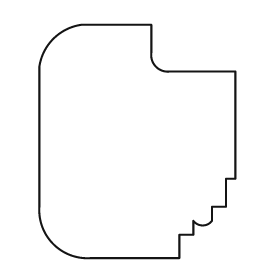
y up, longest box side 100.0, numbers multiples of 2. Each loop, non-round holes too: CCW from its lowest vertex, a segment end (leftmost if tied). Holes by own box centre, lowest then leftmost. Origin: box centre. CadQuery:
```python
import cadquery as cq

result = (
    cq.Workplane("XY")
    .moveTo(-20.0, -50.0)
    .lineTo(18.0, -50.0)
    .lineTo(18.0, -40.0)
    .lineTo(24.0, -40.0)
    .lineTo(24.0, -34.0)
    .threePointArc((28.0, -36.0), (32.0, -34.0))
    .lineTo(32.0, -28.0)
    .lineTo(38.0, -28.0)
    .lineTo(38.0, -16.0)
    .lineTo(42.0, -16.0)
    .lineTo(42.0, 30.0)
    .lineTo(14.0, 30.0)
    .threePointArc((8.0, 32.0), (6.0, 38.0))
    .lineTo(6.0, 50.0)
    .lineTo(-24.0, 50.0)
    .threePointArc((-36.0, 44.0), (-42.0, 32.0))
    .lineTo(-42.0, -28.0)
    .threePointArc((-36.0, -44.0), (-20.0, -50.0))
    .close()
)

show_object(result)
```